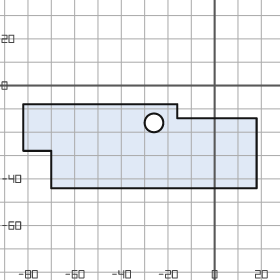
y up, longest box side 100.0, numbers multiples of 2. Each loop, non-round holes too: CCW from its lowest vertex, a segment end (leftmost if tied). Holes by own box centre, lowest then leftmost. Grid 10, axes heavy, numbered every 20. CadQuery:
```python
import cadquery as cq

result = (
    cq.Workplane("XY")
    .moveTo(-70.0, -44.0)
    .lineTo(18.0, -44.0)
    .lineTo(18.0, -14.0)
    .lineTo(-16.0, -14.0)
    .lineTo(-16.0, -8.0)
    .lineTo(-82.0, -8.0)
    .lineTo(-82.0, -28.0)
    .lineTo(-70.0, -28.0)
    .close()
    .moveTo(-26.0, -16.0)
    .circle(4.0)
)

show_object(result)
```